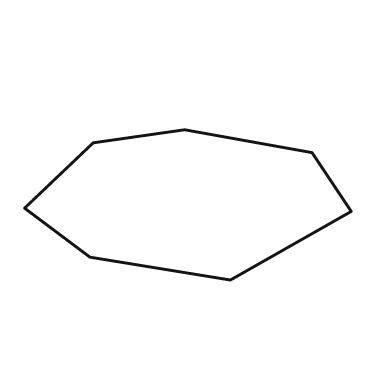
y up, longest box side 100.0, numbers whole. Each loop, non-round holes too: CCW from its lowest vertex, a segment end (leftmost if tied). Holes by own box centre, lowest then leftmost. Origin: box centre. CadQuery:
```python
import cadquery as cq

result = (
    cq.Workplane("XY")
    .moveTo(13.0, -23.0)
    .lineTo(50.0, -2.0)
    .lineTo(38.0, 16.0)
    .lineTo(-1.0, 23.0)
    .lineTo(-29.0, 19.0)
    .lineTo(-50.0, -1.0)
    .lineTo(-30.0, -16.0)
    .close()
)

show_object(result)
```